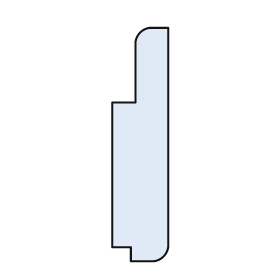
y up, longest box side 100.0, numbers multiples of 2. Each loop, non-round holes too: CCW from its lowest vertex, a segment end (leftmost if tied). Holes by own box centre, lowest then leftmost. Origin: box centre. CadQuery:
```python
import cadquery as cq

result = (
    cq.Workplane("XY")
    .moveTo(-4.0, -50.0)
    .lineTo(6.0, -50.0)
    .threePointArc((10.0, -48.0), (12.0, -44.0))
    .lineTo(12.0, 50.0)
    .lineTo(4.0, 50.0)
    .threePointArc((0.0, 48.0), (-2.0, 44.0))
    .lineTo(-2.0, 18.0)
    .lineTo(-12.0, 18.0)
    .lineTo(-12.0, -44.0)
    .lineTo(-4.0, -44.0)
    .close()
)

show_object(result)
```